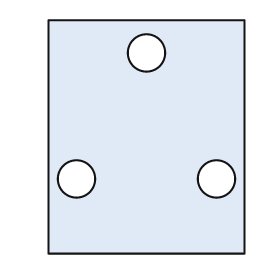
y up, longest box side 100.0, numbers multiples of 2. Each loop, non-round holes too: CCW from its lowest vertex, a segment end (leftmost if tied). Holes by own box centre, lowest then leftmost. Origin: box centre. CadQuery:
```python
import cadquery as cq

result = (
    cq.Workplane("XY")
    .moveTo(-42.0, -50.0)
    .lineTo(42.0, -50.0)
    .lineTo(42.0, 50.0)
    .lineTo(-42.0, 50.0)
    .close()
    .moveTo(-30.0, -18.0)
    .circle(8.0)
    .moveTo(30.0, -18.0)
    .circle(8.0)
    .moveTo(0.0, 36.0)
    .circle(8.0)
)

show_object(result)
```